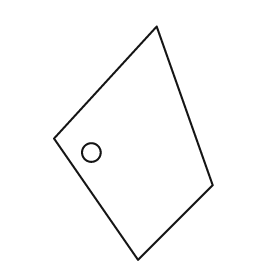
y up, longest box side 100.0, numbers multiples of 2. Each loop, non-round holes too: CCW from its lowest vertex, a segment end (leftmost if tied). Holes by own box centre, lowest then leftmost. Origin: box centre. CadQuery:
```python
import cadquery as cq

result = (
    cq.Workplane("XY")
    .moveTo(2.0, -50.0)
    .lineTo(34.0, -18.0)
    .lineTo(10.0, 50.0)
    .lineTo(-34.0, 2.0)
    .close()
    .moveTo(-18.0, -4.0)
    .circle(4.0)
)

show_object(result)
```